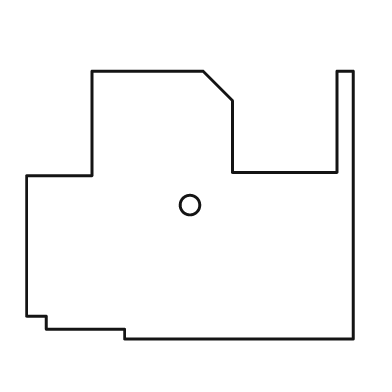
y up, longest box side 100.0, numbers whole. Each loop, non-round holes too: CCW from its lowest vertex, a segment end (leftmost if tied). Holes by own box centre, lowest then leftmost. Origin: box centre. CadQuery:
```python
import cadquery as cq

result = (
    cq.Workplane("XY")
    .moveTo(-20.0, -41.0)
    .lineTo(50.0, -41.0)
    .lineTo(50.0, 41.0)
    .lineTo(45.0, 41.0)
    .lineTo(45.0, 10.0)
    .lineTo(13.0, 10.0)
    .lineTo(13.0, 32.0)
    .lineTo(4.0, 41.0)
    .lineTo(-30.0, 41.0)
    .lineTo(-30.0, 9.0)
    .lineTo(-50.0, 9.0)
    .lineTo(-50.0, -34.0)
    .lineTo(-44.0, -34.0)
    .lineTo(-44.0, -38.0)
    .lineTo(-20.0, -38.0)
    .close()
    .moveTo(0.0, 0.0)
    .circle(3.0)
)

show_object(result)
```